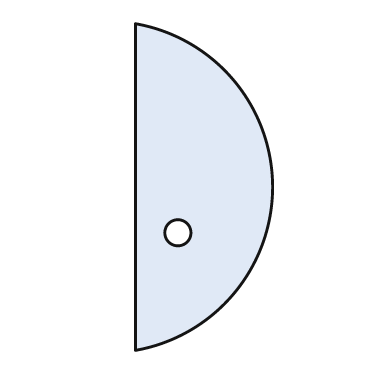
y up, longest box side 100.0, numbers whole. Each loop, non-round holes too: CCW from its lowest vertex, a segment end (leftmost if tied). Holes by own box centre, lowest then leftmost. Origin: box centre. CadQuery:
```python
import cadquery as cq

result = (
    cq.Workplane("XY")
    .moveTo(-21.0, -50.0)
    .threePointArc((21.0, 0.0), (-21.0, 50.0))
    .close()
    .moveTo(-8.0, -14.0)
    .circle(4.0)
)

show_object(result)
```